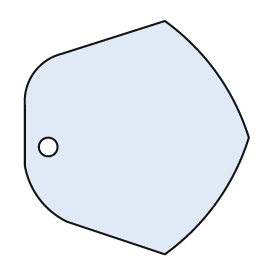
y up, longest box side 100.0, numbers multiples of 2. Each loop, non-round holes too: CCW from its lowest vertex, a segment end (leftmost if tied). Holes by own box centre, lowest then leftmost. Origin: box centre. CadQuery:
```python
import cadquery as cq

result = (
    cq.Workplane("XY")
    .moveTo(12.0, -50.0)
    .threePointArc((34.0, -28.0), (48.0, 0.0))
    .threePointArc((34.0, 28.0), (12.0, 50.0))
    .lineTo(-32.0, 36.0)
    .threePointArc((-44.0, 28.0), (-48.0, 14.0))
    .lineTo(-48.0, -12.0)
    .threePointArc((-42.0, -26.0), (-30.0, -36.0))
    .close()
    .moveTo(-38.0, -4.0)
    .circle(4.0)
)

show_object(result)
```